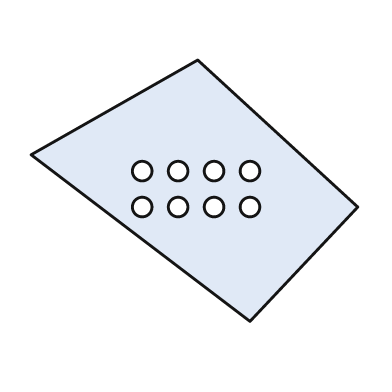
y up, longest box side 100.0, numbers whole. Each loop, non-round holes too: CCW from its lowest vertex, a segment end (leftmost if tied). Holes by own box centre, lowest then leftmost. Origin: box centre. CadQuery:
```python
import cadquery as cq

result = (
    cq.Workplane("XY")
    .moveTo(17.0, -40.0)
    .lineTo(50.0, -5.0)
    .lineTo(1.0, 40.0)
    .lineTo(-50.0, 11.0)
    .close()
    .moveTo(-16.0, -5.0)
    .circle(3.0)
    .moveTo(-5.0, -5.0)
    .circle(3.0)
    .moveTo(6.0, -5.0)
    .circle(3.0)
    .moveTo(17.0, -5.0)
    .circle(3.0)
    .moveTo(-16.0, 6.0)
    .circle(3.0)
    .moveTo(-5.0, 6.0)
    .circle(3.0)
    .moveTo(6.0, 6.0)
    .circle(3.0)
    .moveTo(17.0, 6.0)
    .circle(3.0)
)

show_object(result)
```